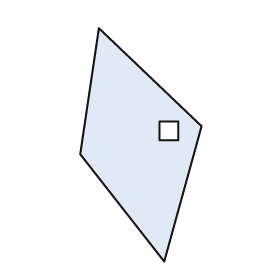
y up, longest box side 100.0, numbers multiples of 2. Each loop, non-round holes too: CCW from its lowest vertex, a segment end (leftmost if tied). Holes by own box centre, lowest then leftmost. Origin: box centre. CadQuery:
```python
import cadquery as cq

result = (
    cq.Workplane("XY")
    .moveTo(10.0, -50.0)
    .lineTo(26.0, 8.0)
    .lineTo(-18.0, 50.0)
    .lineTo(-26.0, -4.0)
    .close()
    .moveTo(8.0, 2.0)
    .lineTo(16.0, 2.0)
    .lineTo(16.0, 10.0)
    .lineTo(8.0, 10.0)
    .close()
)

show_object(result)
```